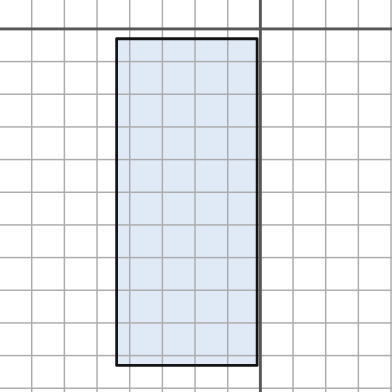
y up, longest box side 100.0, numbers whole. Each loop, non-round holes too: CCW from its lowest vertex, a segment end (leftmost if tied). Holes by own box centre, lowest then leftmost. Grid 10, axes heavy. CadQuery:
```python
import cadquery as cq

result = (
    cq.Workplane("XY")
    .moveTo(-44.0, -103.0)
    .lineTo(-1.0, -103.0)
    .lineTo(-1.0, -3.0)
    .lineTo(-44.0, -3.0)
    .close()
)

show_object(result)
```